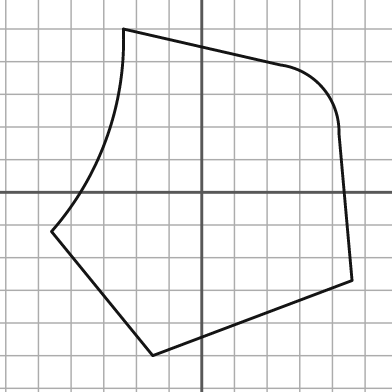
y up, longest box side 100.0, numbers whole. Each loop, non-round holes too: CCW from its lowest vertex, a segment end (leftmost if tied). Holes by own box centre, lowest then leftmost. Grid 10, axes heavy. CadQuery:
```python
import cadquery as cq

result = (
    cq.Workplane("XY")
    .moveTo(-15.0, -50.0)
    .lineTo(46.0, -27.0)
    .lineTo(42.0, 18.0)
    .threePointArc((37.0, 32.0), (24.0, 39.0))
    .lineTo(-24.0, 50.0)
    .threePointArc((-29.0, 17.0), (-46.0, -12.0))
    .close()
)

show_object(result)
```